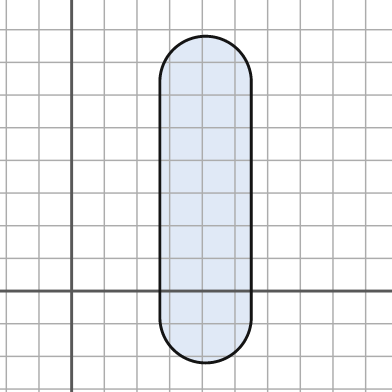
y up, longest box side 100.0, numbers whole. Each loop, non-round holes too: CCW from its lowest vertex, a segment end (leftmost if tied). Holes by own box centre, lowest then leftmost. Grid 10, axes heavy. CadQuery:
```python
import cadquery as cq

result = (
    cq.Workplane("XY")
    .moveTo(27.0, -8.0)
    .threePointArc((41.0, -22.0), (55.0, -8.0))
    .lineTo(55.0, 64.0)
    .threePointArc((41.0, 78.0), (27.0, 64.0))
    .close()
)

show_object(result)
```